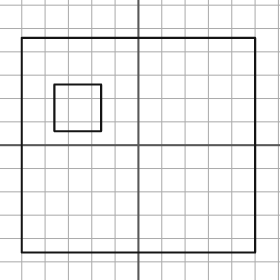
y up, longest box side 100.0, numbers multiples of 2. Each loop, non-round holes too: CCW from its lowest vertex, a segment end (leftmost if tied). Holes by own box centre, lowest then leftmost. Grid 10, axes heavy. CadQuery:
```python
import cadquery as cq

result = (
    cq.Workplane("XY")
    .moveTo(-50.0, -46.0)
    .lineTo(50.0, -46.0)
    .lineTo(50.0, 46.0)
    .lineTo(-50.0, 46.0)
    .close()
    .moveTo(-36.0, 6.0)
    .lineTo(-16.0, 6.0)
    .lineTo(-16.0, 26.0)
    .lineTo(-36.0, 26.0)
    .close()
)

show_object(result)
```